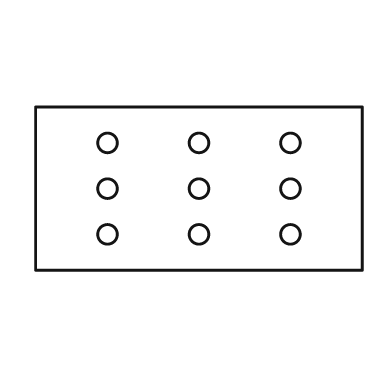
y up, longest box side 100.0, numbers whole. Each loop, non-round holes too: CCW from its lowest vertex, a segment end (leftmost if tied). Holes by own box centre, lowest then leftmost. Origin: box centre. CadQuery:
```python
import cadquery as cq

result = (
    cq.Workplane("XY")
    .moveTo(-50.0, -25.0)
    .lineTo(50.0, -25.0)
    .lineTo(50.0, 25.0)
    .lineTo(-50.0, 25.0)
    .close()
    .moveTo(-28.0, -14.0)
    .circle(3.0)
    .moveTo(0.0, -14.0)
    .circle(3.0)
    .moveTo(28.0, -14.0)
    .circle(3.0)
    .moveTo(-28.0, 0.0)
    .circle(3.0)
    .moveTo(0.0, 0.0)
    .circle(3.0)
    .moveTo(28.0, 0.0)
    .circle(3.0)
    .moveTo(-28.0, 14.0)
    .circle(3.0)
    .moveTo(0.0, 14.0)
    .circle(3.0)
    .moveTo(28.0, 14.0)
    .circle(3.0)
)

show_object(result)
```